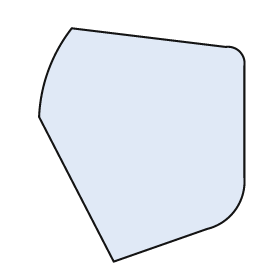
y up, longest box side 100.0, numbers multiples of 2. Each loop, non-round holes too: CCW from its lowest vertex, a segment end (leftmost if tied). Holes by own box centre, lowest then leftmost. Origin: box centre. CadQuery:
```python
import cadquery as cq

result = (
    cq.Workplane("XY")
    .moveTo(-12.0, -50.0)
    .lineTo(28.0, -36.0)
    .threePointArc((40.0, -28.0), (44.0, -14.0))
    .lineTo(44.0, 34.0)
    .threePointArc((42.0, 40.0), (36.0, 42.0))
    .lineTo(-30.0, 50.0)
    .threePointArc((-40.0, 32.0), (-44.0, 12.0))
    .close()
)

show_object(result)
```